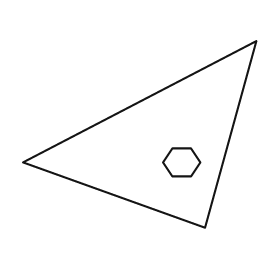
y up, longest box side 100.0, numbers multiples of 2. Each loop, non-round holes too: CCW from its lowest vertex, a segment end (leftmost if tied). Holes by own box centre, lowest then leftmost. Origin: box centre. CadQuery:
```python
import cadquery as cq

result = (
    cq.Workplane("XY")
    .moveTo(28.0, -40.0)
    .lineTo(50.0, 40.0)
    .lineTo(-50.0, -12.0)
    .close()
    .moveTo(14.0, -18.0)
    .lineTo(22.0, -18.0)
    .lineTo(26.0, -12.0)
    .lineTo(22.0, -6.0)
    .lineTo(14.0, -6.0)
    .lineTo(10.0, -12.0)
    .close()
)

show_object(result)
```